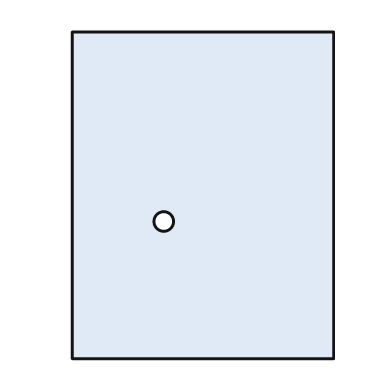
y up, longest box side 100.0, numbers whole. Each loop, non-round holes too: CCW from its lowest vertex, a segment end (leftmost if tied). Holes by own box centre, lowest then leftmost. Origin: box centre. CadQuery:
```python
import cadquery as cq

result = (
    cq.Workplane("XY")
    .moveTo(-40.0, -50.0)
    .lineTo(40.0, -50.0)
    .lineTo(40.0, 50.0)
    .lineTo(-40.0, 50.0)
    .close()
    .moveTo(-12.0, -8.0)
    .circle(3.0)
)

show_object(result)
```